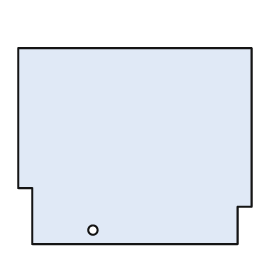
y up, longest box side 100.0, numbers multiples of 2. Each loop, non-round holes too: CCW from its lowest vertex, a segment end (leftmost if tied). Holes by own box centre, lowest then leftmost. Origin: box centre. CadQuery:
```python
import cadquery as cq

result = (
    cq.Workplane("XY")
    .moveTo(-44.0, -42.0)
    .lineTo(44.0, -42.0)
    .lineTo(44.0, -26.0)
    .lineTo(50.0, -26.0)
    .lineTo(50.0, 42.0)
    .lineTo(-50.0, 42.0)
    .lineTo(-50.0, -18.0)
    .lineTo(-44.0, -18.0)
    .close()
    .moveTo(-18.0, -36.0)
    .circle(2.0)
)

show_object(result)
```